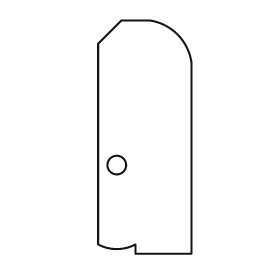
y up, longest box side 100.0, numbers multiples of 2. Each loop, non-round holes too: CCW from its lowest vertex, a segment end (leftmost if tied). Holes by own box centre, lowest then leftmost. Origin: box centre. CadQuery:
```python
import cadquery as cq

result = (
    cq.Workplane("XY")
    .moveTo(-4.0, -50.0)
    .lineTo(20.0, -50.0)
    .lineTo(20.0, 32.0)
    .threePointArc((14.0, 44.0), (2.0, 50.0))
    .lineTo(-10.0, 50.0)
    .lineTo(-20.0, 40.0)
    .lineTo(-20.0, -46.0)
    .threePointArc((-12.0, -48.0), (-4.0, -46.0))
    .close()
    .moveTo(-12.0, -12.0)
    .circle(4.0)
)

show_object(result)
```